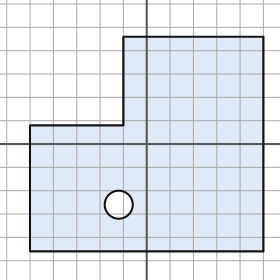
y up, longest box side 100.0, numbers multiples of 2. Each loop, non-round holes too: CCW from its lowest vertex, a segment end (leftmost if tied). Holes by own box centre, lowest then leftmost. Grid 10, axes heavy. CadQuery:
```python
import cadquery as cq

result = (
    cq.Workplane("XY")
    .moveTo(-50.0, -46.0)
    .lineTo(50.0, -46.0)
    .lineTo(50.0, 46.0)
    .lineTo(-10.0, 46.0)
    .lineTo(-10.0, 8.0)
    .lineTo(-50.0, 8.0)
    .close()
    .moveTo(-12.0, -26.0)
    .circle(6.0)
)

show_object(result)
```